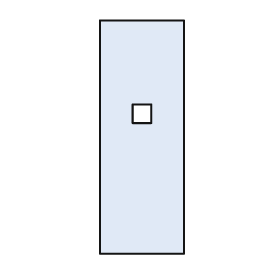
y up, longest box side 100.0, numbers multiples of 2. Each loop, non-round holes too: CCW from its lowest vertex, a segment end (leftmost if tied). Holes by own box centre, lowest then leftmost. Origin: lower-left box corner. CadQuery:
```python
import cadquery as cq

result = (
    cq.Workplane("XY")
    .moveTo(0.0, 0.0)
    .lineTo(36.0, 0.0)
    .lineTo(36.0, 100.0)
    .lineTo(0.0, 100.0)
    .close()
    .moveTo(14.0, 56.0)
    .lineTo(22.0, 56.0)
    .lineTo(22.0, 64.0)
    .lineTo(14.0, 64.0)
    .close()
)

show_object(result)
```